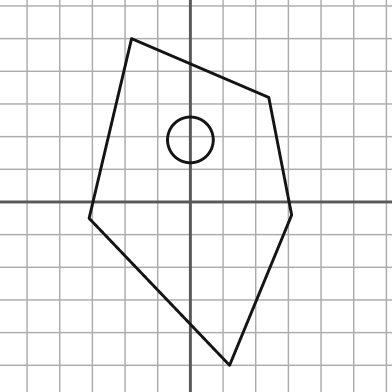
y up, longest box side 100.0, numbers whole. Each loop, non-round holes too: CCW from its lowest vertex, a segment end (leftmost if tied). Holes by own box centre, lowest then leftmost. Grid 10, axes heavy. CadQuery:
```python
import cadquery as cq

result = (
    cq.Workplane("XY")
    .moveTo(12.0, -50.0)
    .lineTo(31.0, -4.0)
    .lineTo(24.0, 32.0)
    .lineTo(-18.0, 50.0)
    .lineTo(-31.0, -5.0)
    .close()
    .moveTo(0.0, 19.0)
    .circle(7.0)
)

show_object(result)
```